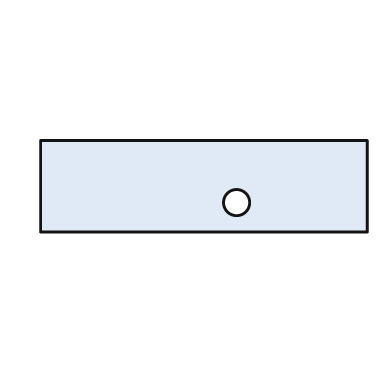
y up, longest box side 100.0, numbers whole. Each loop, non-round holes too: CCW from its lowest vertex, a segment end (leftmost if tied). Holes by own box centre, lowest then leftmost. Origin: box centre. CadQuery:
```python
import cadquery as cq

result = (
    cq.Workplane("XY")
    .moveTo(-50.0, -14.0)
    .lineTo(50.0, -14.0)
    .lineTo(50.0, 14.0)
    .lineTo(-50.0, 14.0)
    .close()
    .moveTo(10.0, -5.0)
    .circle(4.0)
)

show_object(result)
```